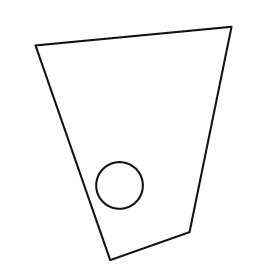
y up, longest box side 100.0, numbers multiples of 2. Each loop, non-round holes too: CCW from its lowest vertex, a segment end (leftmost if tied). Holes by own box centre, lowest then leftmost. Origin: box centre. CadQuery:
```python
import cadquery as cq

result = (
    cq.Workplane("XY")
    .moveTo(-10.0, -50.0)
    .lineTo(24.0, -38.0)
    .lineTo(42.0, 50.0)
    .lineTo(-42.0, 42.0)
    .close()
    .moveTo(-6.0, -18.0)
    .circle(10.0)
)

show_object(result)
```